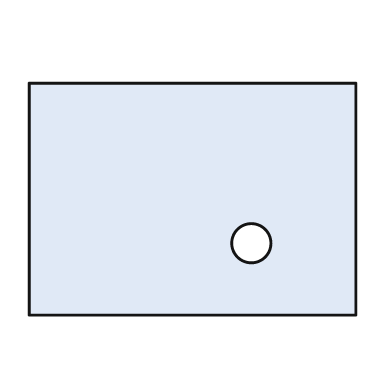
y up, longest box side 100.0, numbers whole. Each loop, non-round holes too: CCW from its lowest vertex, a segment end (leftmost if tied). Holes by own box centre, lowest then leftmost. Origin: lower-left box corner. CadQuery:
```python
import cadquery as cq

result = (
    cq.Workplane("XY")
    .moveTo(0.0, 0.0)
    .lineTo(100.0, 0.0)
    .lineTo(100.0, 71.0)
    .lineTo(0.0, 71.0)
    .close()
    .moveTo(68.0, 22.0)
    .circle(6.0)
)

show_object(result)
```